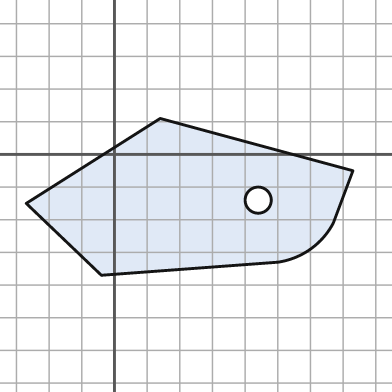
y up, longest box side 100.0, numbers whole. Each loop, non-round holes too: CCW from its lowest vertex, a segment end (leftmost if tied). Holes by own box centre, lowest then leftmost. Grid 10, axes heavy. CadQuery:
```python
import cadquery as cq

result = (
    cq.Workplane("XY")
    .moveTo(-4.0, -37.0)
    .lineTo(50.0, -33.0)
    .threePointArc((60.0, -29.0), (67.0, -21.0))
    .lineTo(73.0, -5.0)
    .lineTo(14.0, 11.0)
    .lineTo(-27.0, -15.0)
    .close()
    .moveTo(44.0, -14.0)
    .circle(4.0)
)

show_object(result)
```